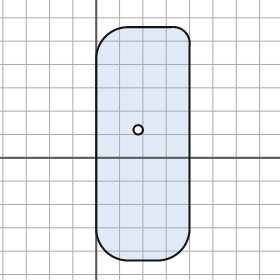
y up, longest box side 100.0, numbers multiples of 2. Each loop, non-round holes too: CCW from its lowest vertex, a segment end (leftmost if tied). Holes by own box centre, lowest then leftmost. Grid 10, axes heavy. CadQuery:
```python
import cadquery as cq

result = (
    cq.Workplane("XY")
    .moveTo(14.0, -44.0)
    .lineTo(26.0, -44.0)
    .threePointArc((36.0, -40.0), (40.0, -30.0))
    .lineTo(40.0, 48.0)
    .threePointArc((38.0, 54.0), (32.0, 56.0))
    .lineTo(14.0, 56.0)
    .threePointArc((4.0, 52.0), (0.0, 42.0))
    .lineTo(0.0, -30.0)
    .threePointArc((4.0, -40.0), (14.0, -44.0))
    .close()
    .moveTo(18.0, 12.0)
    .circle(2.0)
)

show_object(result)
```